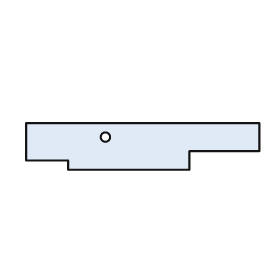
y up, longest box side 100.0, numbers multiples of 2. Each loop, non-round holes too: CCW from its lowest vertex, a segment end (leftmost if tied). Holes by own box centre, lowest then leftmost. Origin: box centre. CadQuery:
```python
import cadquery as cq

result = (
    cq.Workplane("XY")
    .moveTo(-32.0, -10.0)
    .lineTo(20.0, -10.0)
    .lineTo(20.0, -2.0)
    .lineTo(50.0, -2.0)
    .lineTo(50.0, 10.0)
    .lineTo(-50.0, 10.0)
    .lineTo(-50.0, -6.0)
    .lineTo(-32.0, -6.0)
    .close()
    .moveTo(-16.0, 4.0)
    .circle(2.0)
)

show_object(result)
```